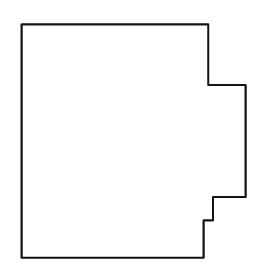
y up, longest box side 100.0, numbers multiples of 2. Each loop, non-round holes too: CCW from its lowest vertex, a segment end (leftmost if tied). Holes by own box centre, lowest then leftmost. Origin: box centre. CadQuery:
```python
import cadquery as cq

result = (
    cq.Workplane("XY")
    .moveTo(-48.0, -50.0)
    .lineTo(30.0, -50.0)
    .lineTo(30.0, -34.0)
    .lineTo(34.0, -34.0)
    .lineTo(34.0, -24.0)
    .lineTo(48.0, -24.0)
    .lineTo(48.0, 24.0)
    .lineTo(32.0, 24.0)
    .lineTo(32.0, 50.0)
    .lineTo(-48.0, 50.0)
    .close()
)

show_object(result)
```